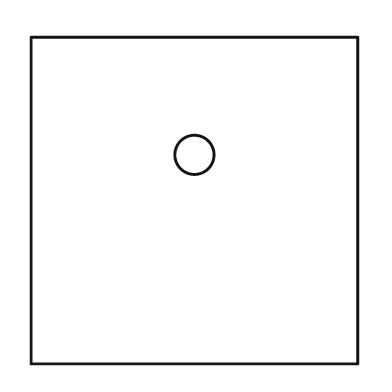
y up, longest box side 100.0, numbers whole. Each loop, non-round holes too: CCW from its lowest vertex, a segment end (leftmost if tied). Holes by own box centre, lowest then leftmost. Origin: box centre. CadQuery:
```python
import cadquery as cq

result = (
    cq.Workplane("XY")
    .moveTo(-50.0, -50.0)
    .lineTo(50.0, -50.0)
    .lineTo(50.0, 50.0)
    .lineTo(-50.0, 50.0)
    .close()
    .moveTo(0.0, 14.0)
    .circle(6.0)
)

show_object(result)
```